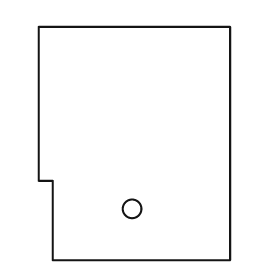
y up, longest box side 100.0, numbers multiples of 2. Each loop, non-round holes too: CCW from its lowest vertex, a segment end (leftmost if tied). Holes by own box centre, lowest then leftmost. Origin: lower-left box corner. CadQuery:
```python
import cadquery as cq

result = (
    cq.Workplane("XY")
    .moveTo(6.0, 0.0)
    .lineTo(82.0, 0.0)
    .lineTo(82.0, 100.0)
    .lineTo(0.0, 100.0)
    .lineTo(0.0, 34.0)
    .lineTo(6.0, 34.0)
    .close()
    .moveTo(40.0, 22.0)
    .circle(4.0)
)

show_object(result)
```